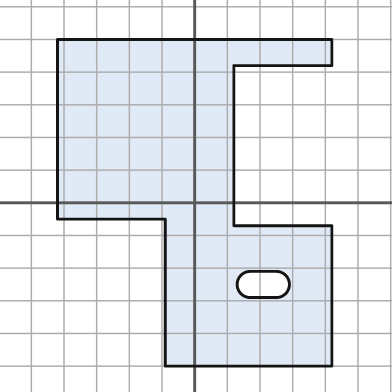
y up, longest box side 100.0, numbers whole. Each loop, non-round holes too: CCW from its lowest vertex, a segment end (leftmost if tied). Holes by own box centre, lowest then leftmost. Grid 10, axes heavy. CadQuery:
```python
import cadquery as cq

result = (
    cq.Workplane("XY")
    .moveTo(-9.0, -50.0)
    .lineTo(42.0, -50.0)
    .lineTo(42.0, -7.0)
    .lineTo(12.0, -7.0)
    .lineTo(12.0, 42.0)
    .lineTo(42.0, 42.0)
    .lineTo(42.0, 50.0)
    .lineTo(-42.0, 50.0)
    .lineTo(-42.0, -5.0)
    .lineTo(-9.0, -5.0)
    .close()
    .moveTo(17.0, -29.0)
    .lineTo(25.0, -29.0)
    .threePointArc((29.0, -25.0), (25.0, -21.0))
    .lineTo(17.0, -21.0)
    .threePointArc((13.0, -25.0), (17.0, -29.0))
    .close()
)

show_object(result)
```